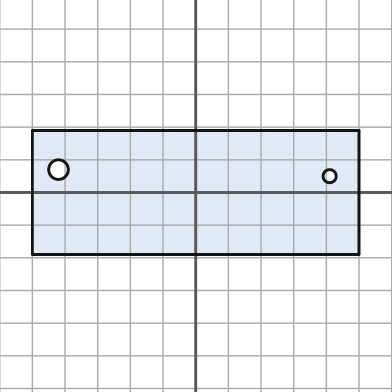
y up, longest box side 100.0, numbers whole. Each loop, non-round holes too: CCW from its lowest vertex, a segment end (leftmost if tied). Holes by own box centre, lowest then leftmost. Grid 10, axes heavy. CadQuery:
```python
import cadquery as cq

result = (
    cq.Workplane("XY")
    .moveTo(-50.0, -19.0)
    .lineTo(50.0, -19.0)
    .lineTo(50.0, 19.0)
    .lineTo(-50.0, 19.0)
    .close()
    .moveTo(41.0, 5.0)
    .circle(2.0)
    .moveTo(-42.0, 7.0)
    .circle(3.0)
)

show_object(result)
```